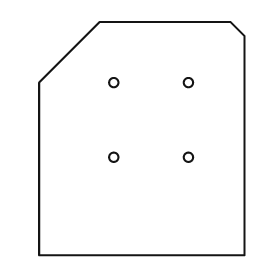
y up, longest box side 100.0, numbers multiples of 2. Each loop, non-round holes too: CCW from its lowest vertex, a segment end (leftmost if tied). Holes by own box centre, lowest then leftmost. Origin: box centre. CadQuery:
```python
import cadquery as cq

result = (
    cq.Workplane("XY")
    .moveTo(-44.0, -50.0)
    .lineTo(44.0, -50.0)
    .lineTo(44.0, 44.0)
    .lineTo(38.0, 50.0)
    .lineTo(-18.0, 50.0)
    .lineTo(-44.0, 24.0)
    .close()
    .moveTo(-12.0, -8.0)
    .circle(2.0)
    .moveTo(20.0, -8.0)
    .circle(2.0)
    .moveTo(-12.0, 24.0)
    .circle(2.0)
    .moveTo(20.0, 24.0)
    .circle(2.0)
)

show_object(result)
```